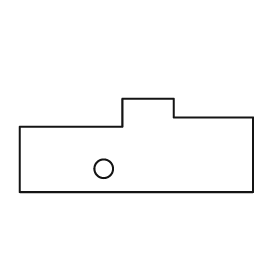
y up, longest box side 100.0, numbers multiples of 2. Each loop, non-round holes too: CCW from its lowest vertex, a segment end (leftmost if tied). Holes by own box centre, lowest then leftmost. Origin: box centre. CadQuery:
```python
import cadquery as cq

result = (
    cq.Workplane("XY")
    .moveTo(-50.0, -20.0)
    .lineTo(50.0, -20.0)
    .lineTo(50.0, 12.0)
    .lineTo(16.0, 12.0)
    .lineTo(16.0, 20.0)
    .lineTo(-6.0, 20.0)
    .lineTo(-6.0, 8.0)
    .lineTo(-50.0, 8.0)
    .close()
    .moveTo(-14.0, -10.0)
    .circle(4.0)
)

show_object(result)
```